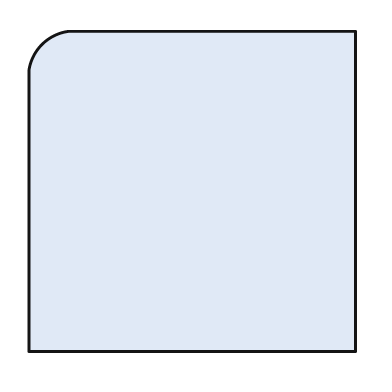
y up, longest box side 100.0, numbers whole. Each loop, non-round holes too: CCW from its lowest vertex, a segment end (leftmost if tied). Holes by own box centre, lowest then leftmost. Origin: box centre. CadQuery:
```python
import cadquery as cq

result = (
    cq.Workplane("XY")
    .moveTo(-50.0, -49.0)
    .lineTo(50.0, -49.0)
    .lineTo(50.0, 49.0)
    .lineTo(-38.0, 49.0)
    .threePointArc((-46.0, 45.0), (-50.0, 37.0))
    .close()
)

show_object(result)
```